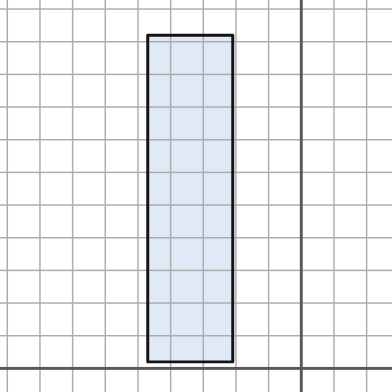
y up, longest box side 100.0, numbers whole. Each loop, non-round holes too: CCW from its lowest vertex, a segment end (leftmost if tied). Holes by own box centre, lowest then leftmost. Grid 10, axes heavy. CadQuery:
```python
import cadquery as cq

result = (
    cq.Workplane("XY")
    .moveTo(-47.0, 2.0)
    .lineTo(-21.0, 2.0)
    .lineTo(-21.0, 102.0)
    .lineTo(-47.0, 102.0)
    .close()
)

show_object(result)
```